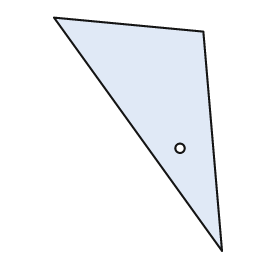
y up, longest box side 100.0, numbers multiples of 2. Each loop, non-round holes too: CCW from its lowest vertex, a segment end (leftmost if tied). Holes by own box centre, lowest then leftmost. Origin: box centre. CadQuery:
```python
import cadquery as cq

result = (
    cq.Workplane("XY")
    .moveTo(36.0, -50.0)
    .lineTo(28.0, 44.0)
    .lineTo(-36.0, 50.0)
    .close()
    .moveTo(18.0, -6.0)
    .circle(2.0)
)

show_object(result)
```